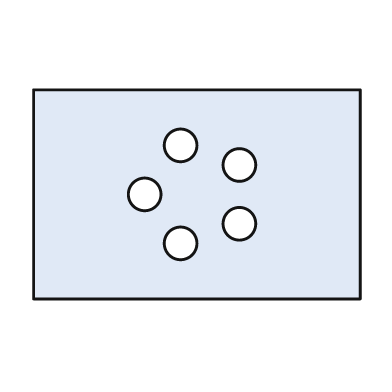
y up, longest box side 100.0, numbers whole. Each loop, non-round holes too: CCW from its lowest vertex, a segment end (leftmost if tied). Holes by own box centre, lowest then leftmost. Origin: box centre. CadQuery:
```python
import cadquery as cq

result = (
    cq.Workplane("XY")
    .moveTo(-50.0, -32.0)
    .lineTo(50.0, -32.0)
    .lineTo(50.0, 32.0)
    .lineTo(-50.0, 32.0)
    .close()
    .moveTo(-5.0, -15.0)
    .circle(5.0)
    .moveTo(13.0, -9.0)
    .circle(5.0)
    .moveTo(-16.0, 0.0)
    .circle(5.0)
    .moveTo(13.0, 9.0)
    .circle(5.0)
    .moveTo(-5.0, 15.0)
    .circle(5.0)
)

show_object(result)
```